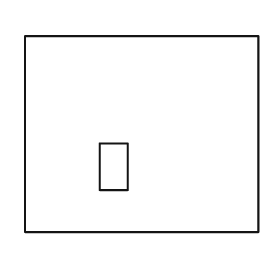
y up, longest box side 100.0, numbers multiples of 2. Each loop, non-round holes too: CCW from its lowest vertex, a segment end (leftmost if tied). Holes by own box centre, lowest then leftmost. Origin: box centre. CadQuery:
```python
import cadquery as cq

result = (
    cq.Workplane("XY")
    .moveTo(-50.0, -42.0)
    .lineTo(50.0, -42.0)
    .lineTo(50.0, 42.0)
    .lineTo(-50.0, 42.0)
    .close()
    .moveTo(-18.0, -24.0)
    .lineTo(-6.0, -24.0)
    .lineTo(-6.0, -4.0)
    .lineTo(-18.0, -4.0)
    .close()
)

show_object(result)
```